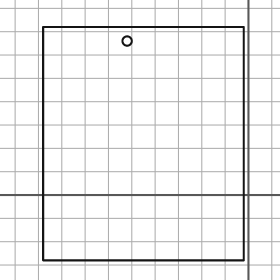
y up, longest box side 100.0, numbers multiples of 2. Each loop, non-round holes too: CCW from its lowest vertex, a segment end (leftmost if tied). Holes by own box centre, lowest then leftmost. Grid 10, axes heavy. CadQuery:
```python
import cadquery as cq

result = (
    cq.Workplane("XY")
    .moveTo(-88.0, -28.0)
    .lineTo(-2.0, -28.0)
    .lineTo(-2.0, 72.0)
    .lineTo(-88.0, 72.0)
    .close()
    .moveTo(-52.0, 66.0)
    .circle(2.0)
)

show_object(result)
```